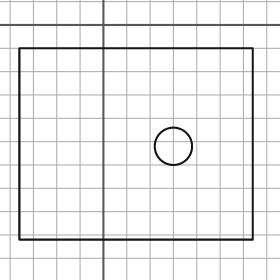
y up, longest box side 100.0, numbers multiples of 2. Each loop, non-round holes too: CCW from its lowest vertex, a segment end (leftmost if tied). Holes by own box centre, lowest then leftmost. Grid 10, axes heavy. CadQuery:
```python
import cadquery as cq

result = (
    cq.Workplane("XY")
    .moveTo(-36.0, -92.0)
    .lineTo(64.0, -92.0)
    .lineTo(64.0, -10.0)
    .lineTo(-36.0, -10.0)
    .close()
    .moveTo(30.0, -52.0)
    .circle(8.0)
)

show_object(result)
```